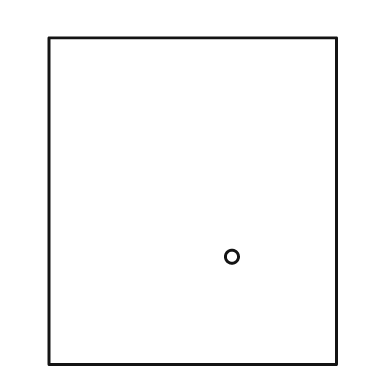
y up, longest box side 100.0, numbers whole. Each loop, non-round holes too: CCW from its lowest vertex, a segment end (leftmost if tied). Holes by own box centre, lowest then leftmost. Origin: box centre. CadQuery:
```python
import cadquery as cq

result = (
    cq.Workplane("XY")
    .moveTo(-44.0, -50.0)
    .lineTo(44.0, -50.0)
    .lineTo(44.0, 50.0)
    .lineTo(-44.0, 50.0)
    .close()
    .moveTo(12.0, -17.0)
    .circle(2.0)
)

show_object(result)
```